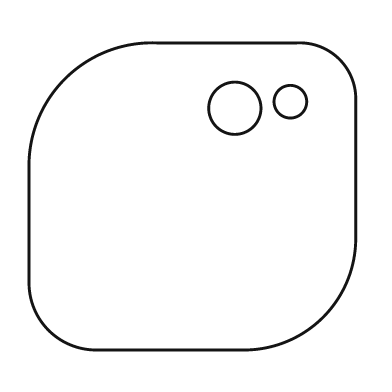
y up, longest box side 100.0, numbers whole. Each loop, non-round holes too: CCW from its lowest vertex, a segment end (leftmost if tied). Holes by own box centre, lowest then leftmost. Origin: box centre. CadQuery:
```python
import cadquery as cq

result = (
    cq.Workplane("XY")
    .moveTo(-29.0, -47.0)
    .lineTo(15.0, -47.0)
    .threePointArc((40.0, -37.0), (50.0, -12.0))
    .lineTo(50.0, 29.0)
    .threePointArc((45.0, 42.0), (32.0, 47.0))
    .lineTo(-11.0, 47.0)
    .threePointArc((-39.0, 36.0), (-50.0, 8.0))
    .lineTo(-50.0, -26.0)
    .threePointArc((-44.0, -41.0), (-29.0, -47.0))
    .close()
    .moveTo(13.0, 27.0)
    .circle(8.0)
    .moveTo(30.0, 29.0)
    .circle(5.0)
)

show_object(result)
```